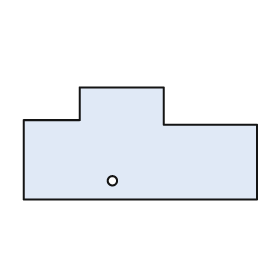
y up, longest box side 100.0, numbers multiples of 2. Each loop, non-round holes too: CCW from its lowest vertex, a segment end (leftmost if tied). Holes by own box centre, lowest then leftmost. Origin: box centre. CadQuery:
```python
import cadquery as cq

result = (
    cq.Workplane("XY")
    .moveTo(-50.0, -24.0)
    .lineTo(50.0, -24.0)
    .lineTo(50.0, 8.0)
    .lineTo(10.0, 8.0)
    .lineTo(10.0, 24.0)
    .lineTo(-26.0, 24.0)
    .lineTo(-26.0, 10.0)
    .lineTo(-50.0, 10.0)
    .close()
    .moveTo(-12.0, -16.0)
    .circle(2.0)
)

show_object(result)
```